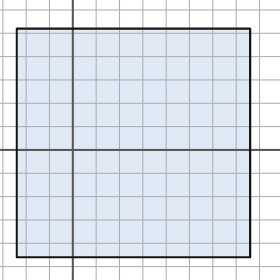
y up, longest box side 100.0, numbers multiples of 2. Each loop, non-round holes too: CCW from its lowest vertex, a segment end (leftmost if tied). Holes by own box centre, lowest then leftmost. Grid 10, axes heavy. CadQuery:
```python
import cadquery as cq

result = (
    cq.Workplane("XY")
    .moveTo(-24.0, -46.0)
    .lineTo(76.0, -46.0)
    .lineTo(76.0, 52.0)
    .lineTo(-24.0, 52.0)
    .close()
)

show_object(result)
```